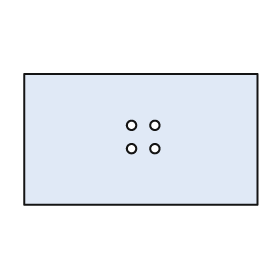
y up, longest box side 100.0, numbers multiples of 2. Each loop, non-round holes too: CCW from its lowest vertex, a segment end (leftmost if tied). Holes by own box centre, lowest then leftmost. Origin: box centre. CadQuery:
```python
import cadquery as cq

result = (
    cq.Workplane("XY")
    .moveTo(-50.0, -28.0)
    .lineTo(50.0, -28.0)
    .lineTo(50.0, 28.0)
    .lineTo(-50.0, 28.0)
    .close()
    .moveTo(-4.0, -4.0)
    .circle(2.0)
    .moveTo(6.0, -4.0)
    .circle(2.0)
    .moveTo(-4.0, 6.0)
    .circle(2.0)
    .moveTo(6.0, 6.0)
    .circle(2.0)
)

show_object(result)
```